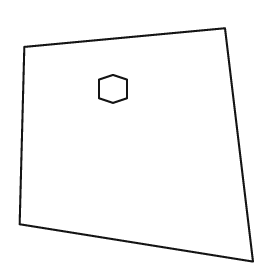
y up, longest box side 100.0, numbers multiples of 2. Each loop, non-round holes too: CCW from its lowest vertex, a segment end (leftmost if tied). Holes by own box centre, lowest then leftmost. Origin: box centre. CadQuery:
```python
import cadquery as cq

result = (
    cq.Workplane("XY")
    .moveTo(50.0, -50.0)
    .lineTo(38.0, 50.0)
    .lineTo(-48.0, 42.0)
    .lineTo(-50.0, -34.0)
    .close()
    .moveTo(-10.0, 18.0)
    .lineTo(-4.0, 20.0)
    .lineTo(-4.0, 28.0)
    .lineTo(-10.0, 30.0)
    .lineTo(-16.0, 28.0)
    .lineTo(-16.0, 20.0)
    .close()
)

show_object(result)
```